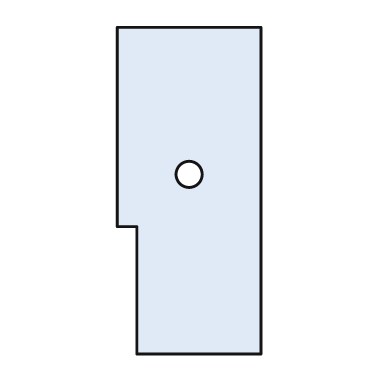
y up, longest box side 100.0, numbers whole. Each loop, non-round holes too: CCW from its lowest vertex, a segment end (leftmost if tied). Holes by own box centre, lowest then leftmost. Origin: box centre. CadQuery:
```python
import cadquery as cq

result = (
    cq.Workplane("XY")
    .moveTo(-16.0, -50.0)
    .lineTo(22.0, -50.0)
    .lineTo(22.0, 50.0)
    .lineTo(-22.0, 50.0)
    .lineTo(-22.0, -11.0)
    .lineTo(-16.0, -11.0)
    .close()
    .moveTo(0.0, 5.0)
    .circle(4.0)
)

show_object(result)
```